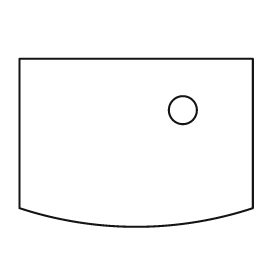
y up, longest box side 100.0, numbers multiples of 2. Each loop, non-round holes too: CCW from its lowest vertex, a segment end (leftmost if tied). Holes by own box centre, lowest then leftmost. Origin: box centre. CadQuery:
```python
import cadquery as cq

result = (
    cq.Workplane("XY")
    .moveTo(-50.0, -28.0)
    .threePointArc((0.0, -36.0), (50.0, -28.0))
    .lineTo(50.0, 36.0)
    .lineTo(-50.0, 36.0)
    .close()
    .moveTo(20.0, 14.0)
    .circle(6.0)
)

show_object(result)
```